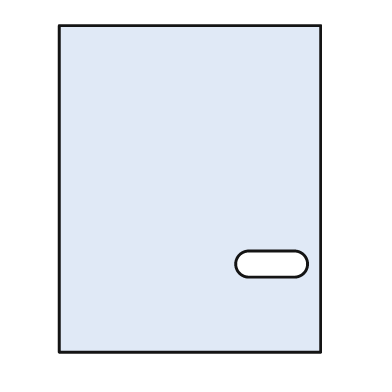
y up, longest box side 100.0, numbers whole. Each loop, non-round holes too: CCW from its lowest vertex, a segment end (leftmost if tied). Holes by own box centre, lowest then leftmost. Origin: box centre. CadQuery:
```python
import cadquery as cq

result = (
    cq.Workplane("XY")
    .moveTo(-40.0, -50.0)
    .lineTo(40.0, -50.0)
    .lineTo(40.0, 50.0)
    .lineTo(-40.0, 50.0)
    .close()
    .moveTo(18.0, -27.0)
    .lineTo(32.0, -27.0)
    .threePointArc((36.0, -23.0), (32.0, -19.0))
    .lineTo(18.0, -19.0)
    .threePointArc((14.0, -23.0), (18.0, -27.0))
    .close()
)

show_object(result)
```